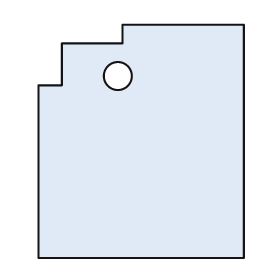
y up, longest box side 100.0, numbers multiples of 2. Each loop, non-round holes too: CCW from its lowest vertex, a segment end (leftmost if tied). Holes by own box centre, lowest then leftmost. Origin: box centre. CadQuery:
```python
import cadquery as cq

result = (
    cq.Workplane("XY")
    .moveTo(-44.0, -50.0)
    .lineTo(44.0, -50.0)
    .lineTo(44.0, 50.0)
    .lineTo(-8.0, 50.0)
    .lineTo(-8.0, 42.0)
    .lineTo(-34.0, 42.0)
    .lineTo(-34.0, 24.0)
    .lineTo(-44.0, 24.0)
    .close()
    .moveTo(-10.0, 28.0)
    .circle(6.0)
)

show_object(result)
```